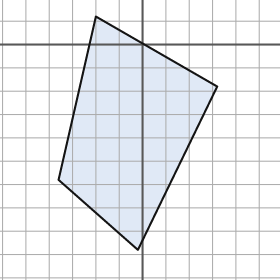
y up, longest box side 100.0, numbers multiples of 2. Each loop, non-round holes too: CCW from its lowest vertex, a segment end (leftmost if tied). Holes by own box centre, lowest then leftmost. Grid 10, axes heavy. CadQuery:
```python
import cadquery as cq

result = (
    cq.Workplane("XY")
    .moveTo(-2.0, -88.0)
    .lineTo(32.0, -18.0)
    .lineTo(-20.0, 12.0)
    .lineTo(-36.0, -58.0)
    .close()
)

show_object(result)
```